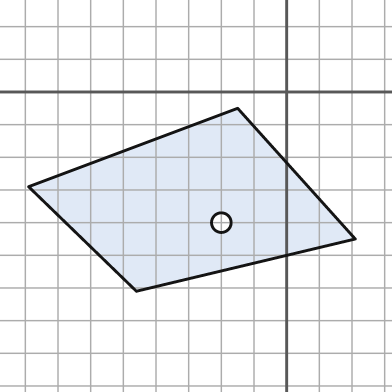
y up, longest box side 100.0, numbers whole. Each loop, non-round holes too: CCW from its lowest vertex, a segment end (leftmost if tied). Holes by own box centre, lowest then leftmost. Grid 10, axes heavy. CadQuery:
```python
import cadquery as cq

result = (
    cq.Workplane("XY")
    .moveTo(-46.0, -61.0)
    .lineTo(21.0, -45.0)
    .lineTo(-15.0, -5.0)
    .lineTo(-79.0, -29.0)
    .close()
    .moveTo(-20.0, -40.0)
    .circle(3.0)
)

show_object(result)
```